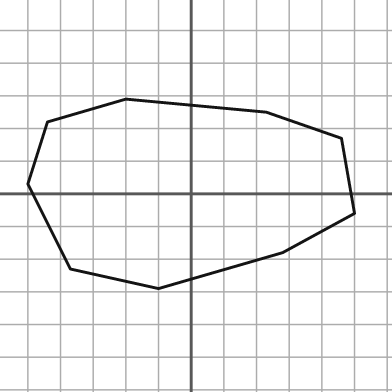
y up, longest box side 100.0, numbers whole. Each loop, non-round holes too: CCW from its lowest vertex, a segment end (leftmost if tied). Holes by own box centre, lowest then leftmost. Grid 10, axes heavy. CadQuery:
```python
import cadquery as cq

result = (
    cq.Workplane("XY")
    .moveTo(-10.0, -29.0)
    .lineTo(28.0, -18.0)
    .lineTo(50.0, -6.0)
    .lineTo(46.0, 17.0)
    .lineTo(23.0, 25.0)
    .lineTo(-20.0, 29.0)
    .lineTo(-44.0, 22.0)
    .lineTo(-50.0, 3.0)
    .lineTo(-37.0, -23.0)
    .close()
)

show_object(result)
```